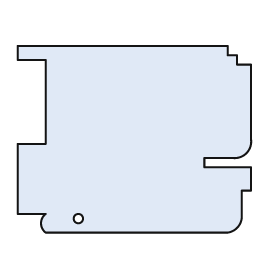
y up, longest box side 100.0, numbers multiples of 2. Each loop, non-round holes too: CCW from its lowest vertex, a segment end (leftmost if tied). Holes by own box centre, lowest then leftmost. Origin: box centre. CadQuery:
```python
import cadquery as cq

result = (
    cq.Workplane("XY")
    .moveTo(-38.0, -40.0)
    .lineTo(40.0, -40.0)
    .threePointArc((44.0, -38.0), (46.0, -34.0))
    .lineTo(46.0, -22.0)
    .lineTo(50.0, -22.0)
    .lineTo(50.0, -12.0)
    .lineTo(30.0, -12.0)
    .lineTo(30.0, -8.0)
    .lineTo(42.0, -8.0)
    .threePointArc((48.0, -6.0), (50.0, 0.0))
    .lineTo(50.0, 32.0)
    .lineTo(44.0, 32.0)
    .lineTo(44.0, 36.0)
    .lineTo(40.0, 36.0)
    .lineTo(40.0, 40.0)
    .lineTo(-50.0, 40.0)
    .lineTo(-50.0, 34.0)
    .lineTo(-38.0, 34.0)
    .lineTo(-38.0, -2.0)
    .lineTo(-50.0, -2.0)
    .lineTo(-50.0, -32.0)
    .lineTo(-38.0, -32.0)
    .threePointArc((-40.0, -36.0), (-38.0, -40.0))
    .close()
    .moveTo(-24.0, -34.0)
    .circle(2.0)
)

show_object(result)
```